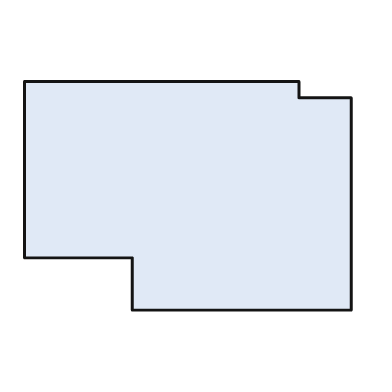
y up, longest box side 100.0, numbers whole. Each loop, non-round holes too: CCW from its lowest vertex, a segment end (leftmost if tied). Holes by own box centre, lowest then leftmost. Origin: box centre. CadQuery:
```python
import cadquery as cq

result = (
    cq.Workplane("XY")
    .moveTo(-17.0, -35.0)
    .lineTo(50.0, -35.0)
    .lineTo(50.0, 30.0)
    .lineTo(34.0, 30.0)
    .lineTo(34.0, 35.0)
    .lineTo(-50.0, 35.0)
    .lineTo(-50.0, -19.0)
    .lineTo(-17.0, -19.0)
    .close()
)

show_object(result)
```